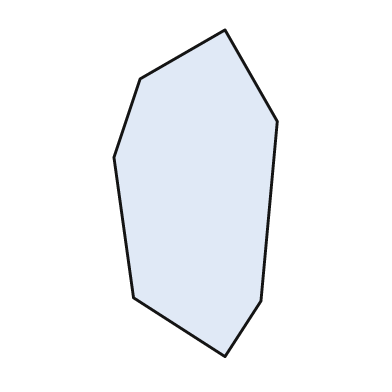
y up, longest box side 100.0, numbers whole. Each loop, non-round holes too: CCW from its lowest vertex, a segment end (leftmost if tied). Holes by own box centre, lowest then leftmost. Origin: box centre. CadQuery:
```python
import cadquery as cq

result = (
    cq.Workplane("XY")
    .moveTo(9.0, -50.0)
    .lineTo(20.0, -33.0)
    .lineTo(25.0, 22.0)
    .lineTo(9.0, 50.0)
    .lineTo(-17.0, 35.0)
    .lineTo(-25.0, 11.0)
    .lineTo(-19.0, -32.0)
    .close()
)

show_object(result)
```